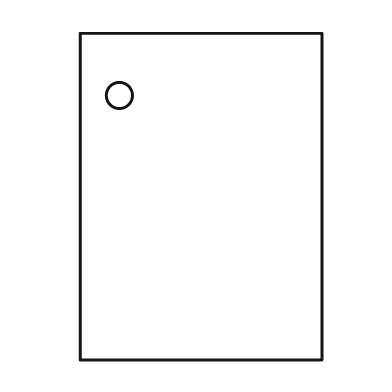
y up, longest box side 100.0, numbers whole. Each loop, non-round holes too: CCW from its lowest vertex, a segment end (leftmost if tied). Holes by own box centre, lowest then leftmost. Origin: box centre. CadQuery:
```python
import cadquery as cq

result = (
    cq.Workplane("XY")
    .moveTo(-37.0, -50.0)
    .lineTo(37.0, -50.0)
    .lineTo(37.0, 50.0)
    .lineTo(-37.0, 50.0)
    .close()
    .moveTo(-25.0, 31.0)
    .circle(4.0)
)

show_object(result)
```